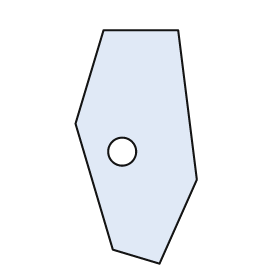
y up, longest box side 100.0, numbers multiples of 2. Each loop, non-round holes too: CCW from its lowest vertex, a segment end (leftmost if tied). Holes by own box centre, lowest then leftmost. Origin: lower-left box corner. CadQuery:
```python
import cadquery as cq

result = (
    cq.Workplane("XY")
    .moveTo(36.0, 0.0)
    .lineTo(52.0, 36.0)
    .lineTo(44.0, 100.0)
    .lineTo(12.0, 100.0)
    .lineTo(0.0, 60.0)
    .lineTo(16.0, 6.0)
    .close()
    .moveTo(20.0, 48.0)
    .circle(6.0)
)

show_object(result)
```